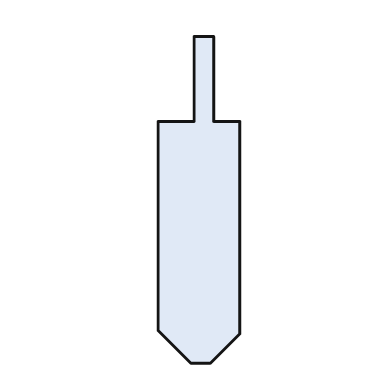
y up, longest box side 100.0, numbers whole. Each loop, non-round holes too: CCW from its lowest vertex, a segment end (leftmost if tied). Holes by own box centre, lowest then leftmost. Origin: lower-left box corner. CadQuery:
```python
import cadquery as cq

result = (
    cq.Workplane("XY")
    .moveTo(10.0, 0.0)
    .lineTo(16.0, 0.0)
    .lineTo(25.0, 9.0)
    .lineTo(25.0, 74.0)
    .lineTo(17.0, 74.0)
    .lineTo(17.0, 100.0)
    .lineTo(11.0, 100.0)
    .lineTo(11.0, 74.0)
    .lineTo(0.0, 74.0)
    .lineTo(0.0, 10.0)
    .close()
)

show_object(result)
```